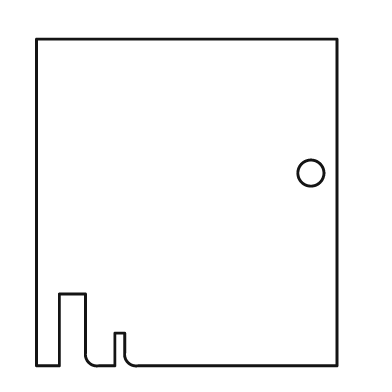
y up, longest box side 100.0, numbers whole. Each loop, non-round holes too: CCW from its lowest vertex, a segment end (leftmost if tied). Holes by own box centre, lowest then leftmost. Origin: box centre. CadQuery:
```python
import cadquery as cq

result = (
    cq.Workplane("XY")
    .moveTo(-46.0, -50.0)
    .lineTo(-39.0, -50.0)
    .lineTo(-39.0, -28.0)
    .lineTo(-31.0, -28.0)
    .lineTo(-31.0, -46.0)
    .threePointArc((-30.0, -49.0), (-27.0, -50.0))
    .lineTo(-22.0, -50.0)
    .lineTo(-22.0, -40.0)
    .lineTo(-19.0, -40.0)
    .lineTo(-19.0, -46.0)
    .threePointArc((-18.0, -49.0), (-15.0, -50.0))
    .lineTo(46.0, -50.0)
    .lineTo(46.0, 50.0)
    .lineTo(-46.0, 50.0)
    .close()
    .moveTo(38.0, 9.0)
    .circle(4.0)
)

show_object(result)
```